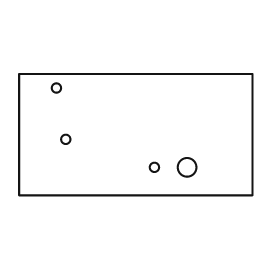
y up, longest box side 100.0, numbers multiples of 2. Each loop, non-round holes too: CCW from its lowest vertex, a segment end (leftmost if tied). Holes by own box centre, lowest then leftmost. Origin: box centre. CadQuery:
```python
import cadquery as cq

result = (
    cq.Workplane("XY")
    .moveTo(-50.0, -26.0)
    .lineTo(50.0, -26.0)
    .lineTo(50.0, 26.0)
    .lineTo(-50.0, 26.0)
    .close()
    .moveTo(8.0, -14.0)
    .circle(2.0)
    .moveTo(22.0, -14.0)
    .circle(4.0)
    .moveTo(-30.0, -2.0)
    .circle(2.0)
    .moveTo(-34.0, 20.0)
    .circle(2.0)
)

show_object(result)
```